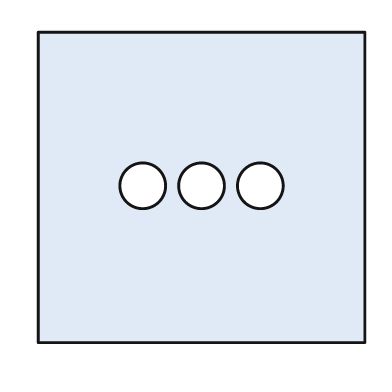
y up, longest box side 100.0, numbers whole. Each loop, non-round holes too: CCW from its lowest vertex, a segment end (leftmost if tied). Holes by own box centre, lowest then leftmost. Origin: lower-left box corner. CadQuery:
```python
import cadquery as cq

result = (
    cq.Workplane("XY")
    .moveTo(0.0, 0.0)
    .lineTo(100.0, 0.0)
    .lineTo(100.0, 95.0)
    .lineTo(0.0, 95.0)
    .close()
    .moveTo(32.0, 48.0)
    .circle(7.0)
    .moveTo(50.0, 48.0)
    .circle(7.0)
    .moveTo(68.0, 48.0)
    .circle(7.0)
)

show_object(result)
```